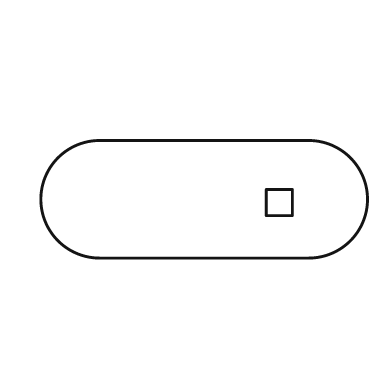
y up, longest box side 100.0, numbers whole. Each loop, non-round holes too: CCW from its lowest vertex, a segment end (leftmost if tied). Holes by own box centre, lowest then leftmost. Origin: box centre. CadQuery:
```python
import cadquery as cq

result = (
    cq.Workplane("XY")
    .moveTo(-32.0, -18.0)
    .lineTo(32.0, -18.0)
    .threePointArc((50.0, 0.0), (32.0, 18.0))
    .lineTo(-32.0, 18.0)
    .threePointArc((-50.0, 0.0), (-32.0, -18.0))
    .close()
    .moveTo(19.0, -5.0)
    .lineTo(27.0, -5.0)
    .lineTo(27.0, 3.0)
    .lineTo(19.0, 3.0)
    .close()
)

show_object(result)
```